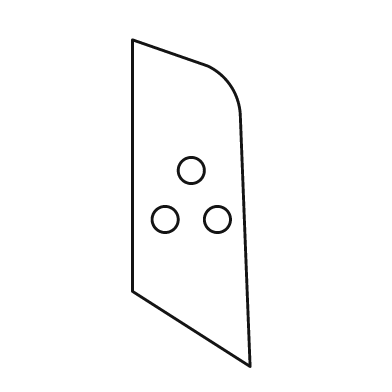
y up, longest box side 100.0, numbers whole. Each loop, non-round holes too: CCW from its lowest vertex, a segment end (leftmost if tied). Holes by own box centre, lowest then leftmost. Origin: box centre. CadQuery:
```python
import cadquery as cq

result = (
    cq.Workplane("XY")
    .moveTo(18.0, -50.0)
    .lineTo(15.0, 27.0)
    .threePointArc((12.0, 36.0), (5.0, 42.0))
    .lineTo(-18.0, 50.0)
    .lineTo(-18.0, -27.0)
    .close()
    .moveTo(-8.0, -5.0)
    .circle(4.0)
    .moveTo(8.0, -5.0)
    .circle(4.0)
    .moveTo(0.0, 10.0)
    .circle(4.0)
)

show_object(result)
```